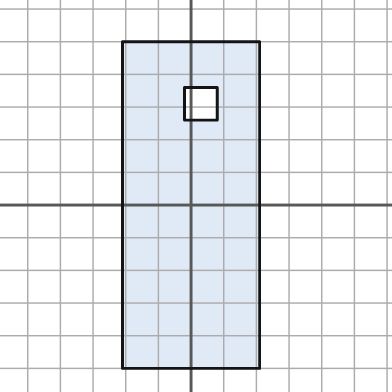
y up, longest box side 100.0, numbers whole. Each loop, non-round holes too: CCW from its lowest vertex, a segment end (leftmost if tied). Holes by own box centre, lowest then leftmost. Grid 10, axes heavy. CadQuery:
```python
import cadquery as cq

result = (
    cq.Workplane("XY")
    .moveTo(-21.0, -50.0)
    .lineTo(21.0, -50.0)
    .lineTo(21.0, 50.0)
    .lineTo(-21.0, 50.0)
    .close()
    .moveTo(-2.0, 26.0)
    .lineTo(8.0, 26.0)
    .lineTo(8.0, 36.0)
    .lineTo(-2.0, 36.0)
    .close()
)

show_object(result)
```